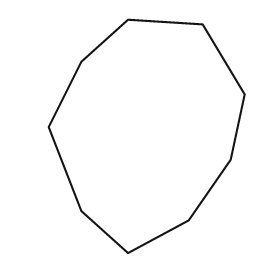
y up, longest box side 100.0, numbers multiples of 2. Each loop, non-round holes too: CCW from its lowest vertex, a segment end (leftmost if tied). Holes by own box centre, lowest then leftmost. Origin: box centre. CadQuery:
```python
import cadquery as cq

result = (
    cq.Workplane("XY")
    .moveTo(-8.0, -50.0)
    .lineTo(18.0, -36.0)
    .lineTo(36.0, -10.0)
    .lineTo(42.0, 18.0)
    .lineTo(24.0, 48.0)
    .lineTo(-8.0, 50.0)
    .lineTo(-28.0, 32.0)
    .lineTo(-42.0, 4.0)
    .lineTo(-28.0, -32.0)
    .close()
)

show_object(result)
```